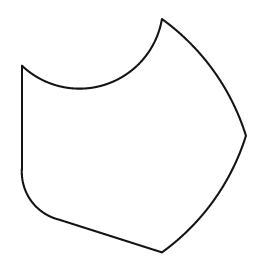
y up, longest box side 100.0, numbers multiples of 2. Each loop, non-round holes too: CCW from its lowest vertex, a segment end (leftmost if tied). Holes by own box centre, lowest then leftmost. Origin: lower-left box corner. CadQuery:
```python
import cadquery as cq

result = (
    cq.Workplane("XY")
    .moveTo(60.0, 0.0)
    .threePointArc((82.0, 22.0), (96.0, 50.0))
    .threePointArc((82.0, 78.0), (60.0, 100.0))
    .threePointArc((36.0, 72.0), (0.0, 80.0))
    .lineTo(0.0, 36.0)
    .threePointArc((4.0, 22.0), (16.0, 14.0))
    .close()
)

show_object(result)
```